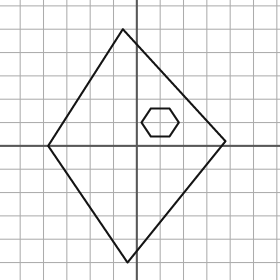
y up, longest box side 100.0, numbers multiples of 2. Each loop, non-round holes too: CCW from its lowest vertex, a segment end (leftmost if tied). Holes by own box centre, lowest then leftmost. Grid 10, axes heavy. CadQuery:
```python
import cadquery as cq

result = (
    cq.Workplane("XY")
    .moveTo(-4.0, -50.0)
    .lineTo(38.0, 2.0)
    .lineTo(-6.0, 50.0)
    .lineTo(-38.0, 0.0)
    .close()
    .moveTo(6.0, 4.0)
    .lineTo(14.0, 4.0)
    .lineTo(18.0, 10.0)
    .lineTo(14.0, 16.0)
    .lineTo(6.0, 16.0)
    .lineTo(2.0, 10.0)
    .close()
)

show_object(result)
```